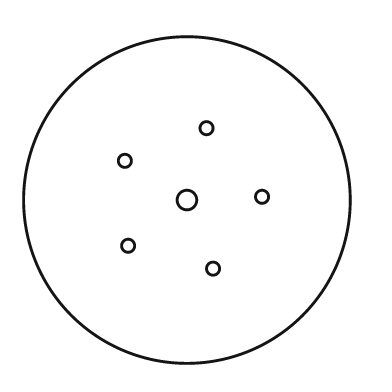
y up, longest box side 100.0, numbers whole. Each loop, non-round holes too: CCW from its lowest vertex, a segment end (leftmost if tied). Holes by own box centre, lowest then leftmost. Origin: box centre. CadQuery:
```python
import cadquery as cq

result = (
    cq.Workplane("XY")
    .moveTo(0.0, 0.0)
    .circle(50.0)
    .moveTo(8.0, -21.0)
    .circle(2.0)
    .moveTo(-18.0, -14.0)
    .circle(2.0)
    .moveTo(0.0, 0.0)
    .circle(3.0)
    .moveTo(23.0, 1.0)
    .circle(2.0)
    .moveTo(-19.0, 12.0)
    .circle(2.0)
    .moveTo(6.0, 22.0)
    .circle(2.0)
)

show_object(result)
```